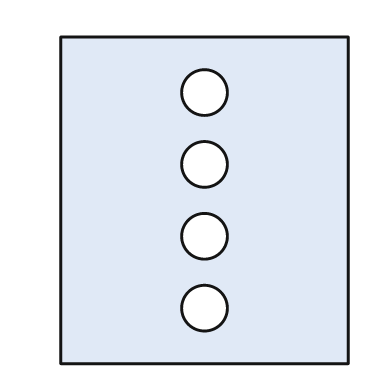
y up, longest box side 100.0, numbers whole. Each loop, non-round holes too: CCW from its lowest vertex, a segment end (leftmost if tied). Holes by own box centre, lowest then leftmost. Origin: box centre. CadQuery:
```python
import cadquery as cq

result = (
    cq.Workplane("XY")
    .moveTo(-44.0, -50.0)
    .lineTo(44.0, -50.0)
    .lineTo(44.0, 50.0)
    .lineTo(-44.0, 50.0)
    .close()
    .moveTo(0.0, -33.0)
    .circle(7.0)
    .moveTo(0.0, -11.0)
    .circle(7.0)
    .moveTo(0.0, 11.0)
    .circle(7.0)
    .moveTo(0.0, 33.0)
    .circle(7.0)
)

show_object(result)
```